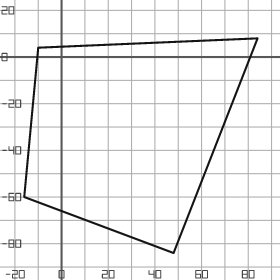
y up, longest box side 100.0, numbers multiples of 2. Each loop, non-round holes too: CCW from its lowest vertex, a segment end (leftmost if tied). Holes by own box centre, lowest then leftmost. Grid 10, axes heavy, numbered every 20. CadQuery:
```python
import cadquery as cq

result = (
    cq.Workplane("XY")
    .moveTo(48.0, -84.0)
    .lineTo(84.0, 8.0)
    .lineTo(-10.0, 4.0)
    .lineTo(-16.0, -60.0)
    .close()
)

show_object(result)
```